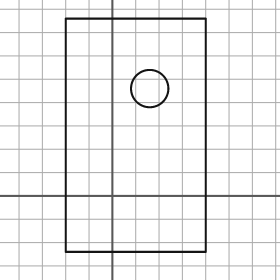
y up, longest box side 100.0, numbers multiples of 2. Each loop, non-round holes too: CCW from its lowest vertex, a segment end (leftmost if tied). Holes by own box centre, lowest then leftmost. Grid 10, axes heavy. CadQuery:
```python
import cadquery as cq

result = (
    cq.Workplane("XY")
    .moveTo(-20.0, -24.0)
    .lineTo(40.0, -24.0)
    .lineTo(40.0, 76.0)
    .lineTo(-20.0, 76.0)
    .close()
    .moveTo(16.0, 46.0)
    .circle(8.0)
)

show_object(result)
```